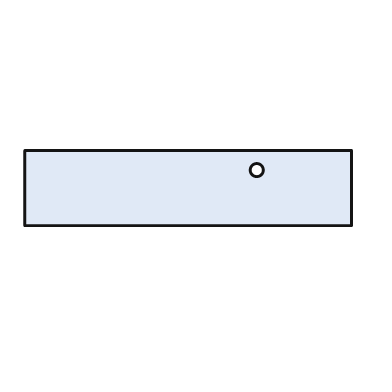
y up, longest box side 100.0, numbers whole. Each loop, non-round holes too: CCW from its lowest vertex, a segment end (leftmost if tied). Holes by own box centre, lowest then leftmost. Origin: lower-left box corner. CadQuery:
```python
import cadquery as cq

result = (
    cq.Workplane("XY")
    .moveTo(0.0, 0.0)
    .lineTo(100.0, 0.0)
    .lineTo(100.0, 23.0)
    .lineTo(0.0, 23.0)
    .close()
    .moveTo(71.0, 17.0)
    .circle(2.0)
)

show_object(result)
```